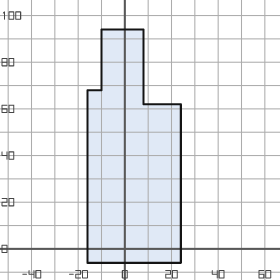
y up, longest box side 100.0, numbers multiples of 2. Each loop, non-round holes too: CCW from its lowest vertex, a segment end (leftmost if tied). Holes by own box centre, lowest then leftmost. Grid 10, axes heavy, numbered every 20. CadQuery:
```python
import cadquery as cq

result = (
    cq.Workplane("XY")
    .moveTo(-16.0, -6.0)
    .lineTo(24.0, -6.0)
    .lineTo(24.0, 62.0)
    .lineTo(8.0, 62.0)
    .lineTo(8.0, 94.0)
    .lineTo(-10.0, 94.0)
    .lineTo(-10.0, 68.0)
    .lineTo(-16.0, 68.0)
    .close()
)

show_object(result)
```